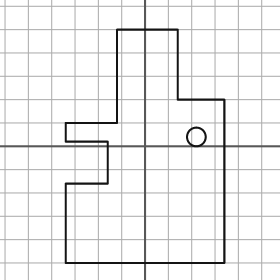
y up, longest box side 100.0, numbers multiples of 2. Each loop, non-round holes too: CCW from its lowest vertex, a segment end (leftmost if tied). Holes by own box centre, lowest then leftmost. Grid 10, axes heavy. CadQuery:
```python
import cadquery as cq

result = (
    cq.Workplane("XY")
    .moveTo(-34.0, -50.0)
    .lineTo(34.0, -50.0)
    .lineTo(34.0, 20.0)
    .lineTo(14.0, 20.0)
    .lineTo(14.0, 50.0)
    .lineTo(-12.0, 50.0)
    .lineTo(-12.0, 10.0)
    .lineTo(-34.0, 10.0)
    .lineTo(-34.0, 2.0)
    .lineTo(-16.0, 2.0)
    .lineTo(-16.0, -16.0)
    .lineTo(-34.0, -16.0)
    .close()
    .moveTo(22.0, 4.0)
    .circle(4.0)
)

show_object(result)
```